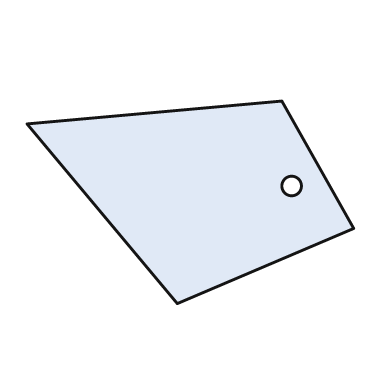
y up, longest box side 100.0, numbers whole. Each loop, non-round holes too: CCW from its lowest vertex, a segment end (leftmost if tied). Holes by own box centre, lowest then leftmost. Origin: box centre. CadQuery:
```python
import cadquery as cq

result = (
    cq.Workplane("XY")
    .moveTo(-4.0, -31.0)
    .lineTo(50.0, -8.0)
    .lineTo(28.0, 31.0)
    .lineTo(-50.0, 24.0)
    .close()
    .moveTo(31.0, 5.0)
    .circle(3.0)
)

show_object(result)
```